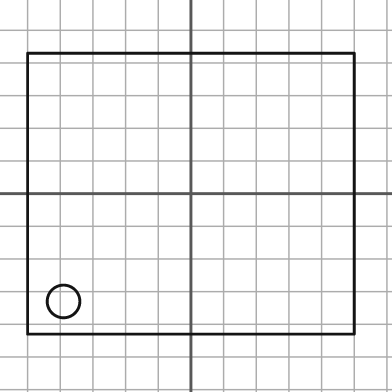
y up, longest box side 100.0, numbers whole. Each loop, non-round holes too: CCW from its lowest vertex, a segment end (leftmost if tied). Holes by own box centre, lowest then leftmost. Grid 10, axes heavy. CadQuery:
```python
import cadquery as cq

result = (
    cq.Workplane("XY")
    .moveTo(-50.0, -43.0)
    .lineTo(50.0, -43.0)
    .lineTo(50.0, 43.0)
    .lineTo(-50.0, 43.0)
    .close()
    .moveTo(-39.0, -33.0)
    .circle(5.0)
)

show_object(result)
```